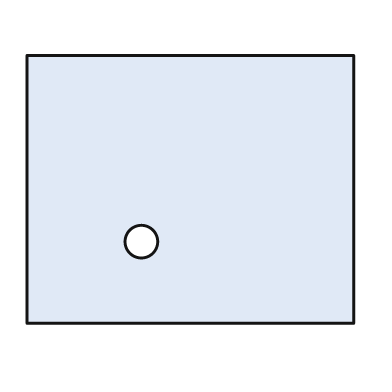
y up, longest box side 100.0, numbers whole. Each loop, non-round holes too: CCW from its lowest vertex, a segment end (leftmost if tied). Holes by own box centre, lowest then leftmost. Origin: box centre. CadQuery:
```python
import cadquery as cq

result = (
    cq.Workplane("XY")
    .moveTo(-50.0, -41.0)
    .lineTo(50.0, -41.0)
    .lineTo(50.0, 41.0)
    .lineTo(-50.0, 41.0)
    .close()
    .moveTo(-15.0, -16.0)
    .circle(5.0)
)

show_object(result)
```